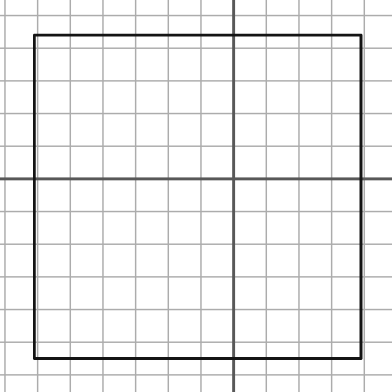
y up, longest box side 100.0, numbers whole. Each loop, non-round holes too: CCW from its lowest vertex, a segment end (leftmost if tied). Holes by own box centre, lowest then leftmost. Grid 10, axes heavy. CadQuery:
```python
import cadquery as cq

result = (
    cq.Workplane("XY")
    .moveTo(-61.0, -55.0)
    .lineTo(39.0, -55.0)
    .lineTo(39.0, 44.0)
    .lineTo(-61.0, 44.0)
    .close()
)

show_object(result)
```